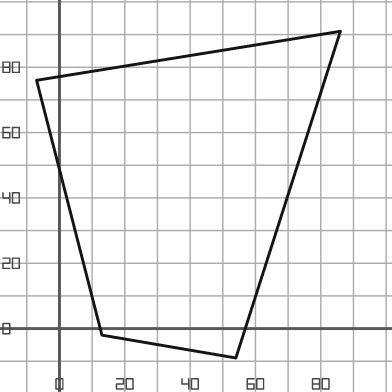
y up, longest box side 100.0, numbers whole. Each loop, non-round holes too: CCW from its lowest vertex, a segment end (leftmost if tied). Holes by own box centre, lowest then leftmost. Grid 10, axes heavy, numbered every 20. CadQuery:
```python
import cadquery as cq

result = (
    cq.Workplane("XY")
    .moveTo(54.0, -9.0)
    .lineTo(86.0, 91.0)
    .lineTo(-7.0, 76.0)
    .lineTo(13.0, -2.0)
    .close()
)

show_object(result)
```